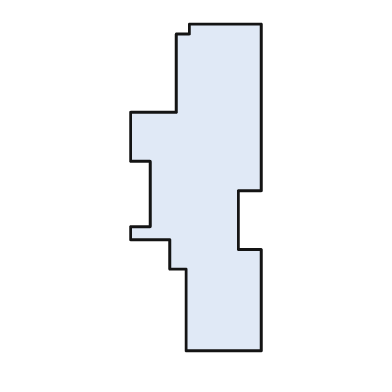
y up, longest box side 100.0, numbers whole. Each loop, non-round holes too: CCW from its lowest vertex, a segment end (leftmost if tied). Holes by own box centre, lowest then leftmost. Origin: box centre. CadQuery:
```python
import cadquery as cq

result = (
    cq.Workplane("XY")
    .moveTo(-3.0, -50.0)
    .lineTo(20.0, -50.0)
    .lineTo(20.0, -19.0)
    .lineTo(13.0, -19.0)
    .lineTo(13.0, -1.0)
    .lineTo(20.0, -1.0)
    .lineTo(20.0, 50.0)
    .lineTo(-2.0, 50.0)
    .lineTo(-2.0, 47.0)
    .lineTo(-6.0, 47.0)
    .lineTo(-6.0, 23.0)
    .lineTo(-20.0, 23.0)
    .lineTo(-20.0, 8.0)
    .lineTo(-14.0, 8.0)
    .lineTo(-14.0, -12.0)
    .lineTo(-20.0, -12.0)
    .lineTo(-20.0, -16.0)
    .lineTo(-8.0, -16.0)
    .lineTo(-8.0, -25.0)
    .lineTo(-3.0, -25.0)
    .close()
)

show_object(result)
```